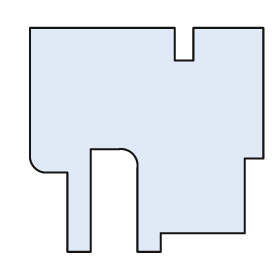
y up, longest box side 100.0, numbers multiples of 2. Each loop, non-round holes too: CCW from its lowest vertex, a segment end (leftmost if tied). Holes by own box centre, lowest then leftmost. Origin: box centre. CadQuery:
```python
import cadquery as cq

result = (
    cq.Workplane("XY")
    .moveTo(-34.0, -48.0)
    .lineTo(-24.0, -48.0)
    .lineTo(-24.0, -4.0)
    .lineTo(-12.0, -4.0)
    .threePointArc((-6.0, -6.0), (-4.0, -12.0))
    .lineTo(-4.0, -48.0)
    .lineTo(6.0, -48.0)
    .lineTo(6.0, -40.0)
    .lineTo(42.0, -40.0)
    .lineTo(42.0, -8.0)
    .lineTo(50.0, -8.0)
    .lineTo(50.0, 48.0)
    .lineTo(20.0, 48.0)
    .lineTo(20.0, 34.0)
    .lineTo(12.0, 34.0)
    .lineTo(12.0, 48.0)
    .lineTo(-50.0, 48.0)
    .lineTo(-50.0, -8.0)
    .threePointArc((-48.0, -12.0), (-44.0, -14.0))
    .lineTo(-34.0, -14.0)
    .close()
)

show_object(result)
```